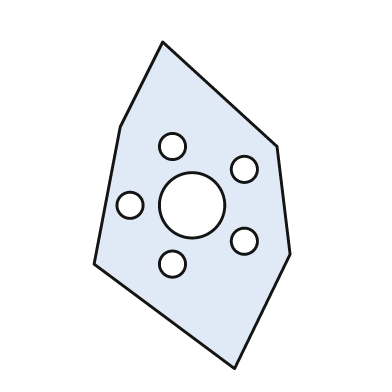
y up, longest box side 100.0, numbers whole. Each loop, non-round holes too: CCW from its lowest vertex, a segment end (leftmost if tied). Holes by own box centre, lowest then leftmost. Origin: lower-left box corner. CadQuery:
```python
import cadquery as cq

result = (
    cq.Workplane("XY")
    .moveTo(43.0, 0.0)
    .lineTo(60.0, 35.0)
    .lineTo(56.0, 68.0)
    .lineTo(21.0, 100.0)
    .lineTo(8.0, 74.0)
    .lineTo(0.0, 32.0)
    .close()
    .moveTo(24.0, 32.0)
    .circle(4.0)
    .moveTo(46.0, 39.0)
    .circle(4.0)
    .moveTo(11.0, 50.0)
    .circle(4.0)
    .moveTo(30.0, 50.0)
    .circle(10.0)
    .moveTo(46.0, 61.0)
    .circle(4.0)
    .moveTo(24.0, 68.0)
    .circle(4.0)
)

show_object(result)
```